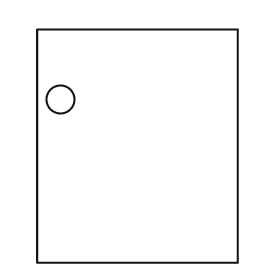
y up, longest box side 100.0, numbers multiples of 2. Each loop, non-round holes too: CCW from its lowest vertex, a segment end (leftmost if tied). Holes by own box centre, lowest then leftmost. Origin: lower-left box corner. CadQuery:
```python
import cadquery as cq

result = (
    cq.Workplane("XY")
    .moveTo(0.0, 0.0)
    .lineTo(86.0, 0.0)
    .lineTo(86.0, 100.0)
    .lineTo(0.0, 100.0)
    .close()
    .moveTo(10.0, 70.0)
    .circle(6.0)
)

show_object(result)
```